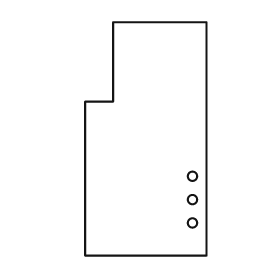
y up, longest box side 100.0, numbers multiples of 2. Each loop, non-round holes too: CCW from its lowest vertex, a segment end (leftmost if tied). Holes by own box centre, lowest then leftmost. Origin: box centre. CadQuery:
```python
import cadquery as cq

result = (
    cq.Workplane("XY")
    .moveTo(-26.0, -50.0)
    .lineTo(26.0, -50.0)
    .lineTo(26.0, 50.0)
    .lineTo(-14.0, 50.0)
    .lineTo(-14.0, 16.0)
    .lineTo(-26.0, 16.0)
    .close()
    .moveTo(20.0, -36.0)
    .circle(2.0)
    .moveTo(20.0, -26.0)
    .circle(2.0)
    .moveTo(20.0, -16.0)
    .circle(2.0)
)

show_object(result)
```